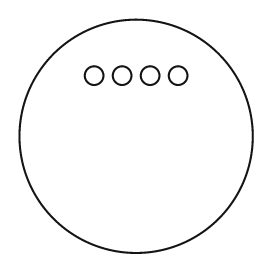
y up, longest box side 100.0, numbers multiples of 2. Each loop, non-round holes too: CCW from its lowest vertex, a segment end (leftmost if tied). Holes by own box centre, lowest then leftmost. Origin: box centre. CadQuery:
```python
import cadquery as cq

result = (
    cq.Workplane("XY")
    .moveTo(0.0, 0.0)
    .circle(50.0)
    .moveTo(-18.0, 26.0)
    .circle(4.0)
    .moveTo(-6.0, 26.0)
    .circle(4.0)
    .moveTo(6.0, 26.0)
    .circle(4.0)
    .moveTo(18.0, 26.0)
    .circle(4.0)
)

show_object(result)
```